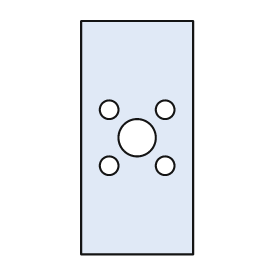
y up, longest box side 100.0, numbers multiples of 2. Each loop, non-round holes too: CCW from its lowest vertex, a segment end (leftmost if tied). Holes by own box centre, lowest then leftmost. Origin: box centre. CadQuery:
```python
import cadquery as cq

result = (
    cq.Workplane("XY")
    .moveTo(-24.0, -50.0)
    .lineTo(24.0, -50.0)
    .lineTo(24.0, 50.0)
    .lineTo(-24.0, 50.0)
    .close()
    .moveTo(-12.0, -12.0)
    .circle(4.0)
    .moveTo(12.0, -12.0)
    .circle(4.0)
    .moveTo(0.0, 0.0)
    .circle(8.0)
    .moveTo(-12.0, 12.0)
    .circle(4.0)
    .moveTo(12.0, 12.0)
    .circle(4.0)
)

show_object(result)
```